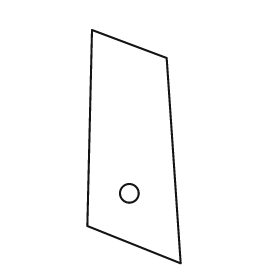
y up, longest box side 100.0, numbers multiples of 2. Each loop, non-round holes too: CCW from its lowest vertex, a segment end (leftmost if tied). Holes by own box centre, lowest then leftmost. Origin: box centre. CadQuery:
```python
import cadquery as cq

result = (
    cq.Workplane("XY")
    .moveTo(20.0, -50.0)
    .lineTo(14.0, 38.0)
    .lineTo(-18.0, 50.0)
    .lineTo(-20.0, -34.0)
    .close()
    .moveTo(-2.0, -20.0)
    .circle(4.0)
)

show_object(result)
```